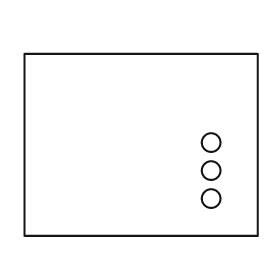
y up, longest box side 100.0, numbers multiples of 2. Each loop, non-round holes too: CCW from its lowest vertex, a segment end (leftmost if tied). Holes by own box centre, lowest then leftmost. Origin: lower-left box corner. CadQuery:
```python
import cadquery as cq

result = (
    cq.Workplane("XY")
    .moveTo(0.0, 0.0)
    .lineTo(100.0, 0.0)
    .lineTo(100.0, 78.0)
    .lineTo(0.0, 78.0)
    .close()
    .moveTo(80.0, 16.0)
    .circle(4.0)
    .moveTo(80.0, 28.0)
    .circle(4.0)
    .moveTo(80.0, 40.0)
    .circle(4.0)
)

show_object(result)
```